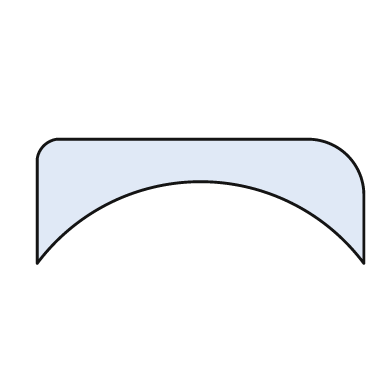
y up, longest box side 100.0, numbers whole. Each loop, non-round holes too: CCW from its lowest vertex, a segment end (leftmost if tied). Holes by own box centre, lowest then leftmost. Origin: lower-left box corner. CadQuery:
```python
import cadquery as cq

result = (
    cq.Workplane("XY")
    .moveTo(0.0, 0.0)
    .threePointArc((50.0, 25.0), (100.0, 0.0))
    .lineTo(100.0, 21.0)
    .threePointArc((95.0, 33.0), (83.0, 38.0))
    .lineTo(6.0, 38.0)
    .threePointArc((2.0, 36.0), (0.0, 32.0))
    .close()
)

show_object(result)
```